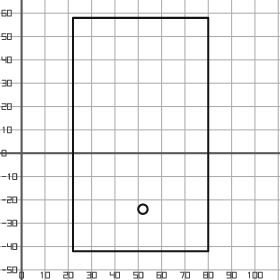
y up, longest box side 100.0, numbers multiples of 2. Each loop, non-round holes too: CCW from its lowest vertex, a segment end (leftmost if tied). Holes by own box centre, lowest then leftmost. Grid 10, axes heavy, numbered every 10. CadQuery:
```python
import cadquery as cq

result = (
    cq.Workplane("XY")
    .moveTo(22.0, -42.0)
    .lineTo(80.0, -42.0)
    .lineTo(80.0, 58.0)
    .lineTo(22.0, 58.0)
    .close()
    .moveTo(52.0, -24.0)
    .circle(2.0)
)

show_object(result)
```